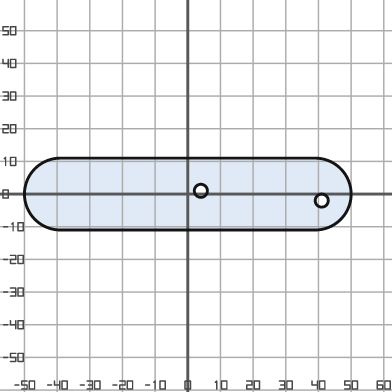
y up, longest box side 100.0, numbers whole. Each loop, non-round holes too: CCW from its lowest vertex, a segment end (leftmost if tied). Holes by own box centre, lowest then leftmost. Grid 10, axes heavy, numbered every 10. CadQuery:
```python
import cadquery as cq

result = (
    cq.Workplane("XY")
    .moveTo(-39.0, -11.0)
    .lineTo(39.0, -11.0)
    .threePointArc((50.0, 0.0), (39.0, 11.0))
    .lineTo(-39.0, 11.0)
    .threePointArc((-50.0, 0.0), (-39.0, -11.0))
    .close()
    .moveTo(41.0, -2.0)
    .circle(2.0)
    .moveTo(4.0, 1.0)
    .circle(2.0)
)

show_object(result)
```